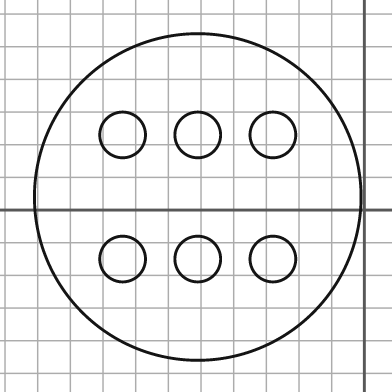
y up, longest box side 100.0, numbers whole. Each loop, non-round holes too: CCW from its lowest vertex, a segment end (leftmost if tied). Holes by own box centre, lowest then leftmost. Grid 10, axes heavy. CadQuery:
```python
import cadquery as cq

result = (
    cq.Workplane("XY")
    .moveTo(-51.0, 4.0)
    .circle(50.0)
    .moveTo(-74.0, -15.0)
    .circle(7.0)
    .moveTo(-51.0, -15.0)
    .circle(7.0)
    .moveTo(-28.0, -15.0)
    .circle(7.0)
    .moveTo(-74.0, 23.0)
    .circle(7.0)
    .moveTo(-51.0, 23.0)
    .circle(7.0)
    .moveTo(-28.0, 23.0)
    .circle(7.0)
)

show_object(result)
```